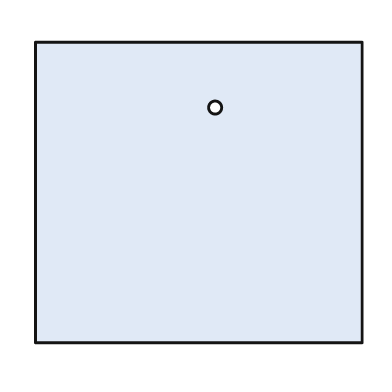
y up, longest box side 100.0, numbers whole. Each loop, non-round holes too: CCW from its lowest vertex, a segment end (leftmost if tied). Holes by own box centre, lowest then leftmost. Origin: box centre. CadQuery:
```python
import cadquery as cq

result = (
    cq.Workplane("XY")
    .moveTo(-50.0, -46.0)
    .lineTo(50.0, -46.0)
    .lineTo(50.0, 46.0)
    .lineTo(-50.0, 46.0)
    .close()
    .moveTo(5.0, 26.0)
    .circle(2.0)
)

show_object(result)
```